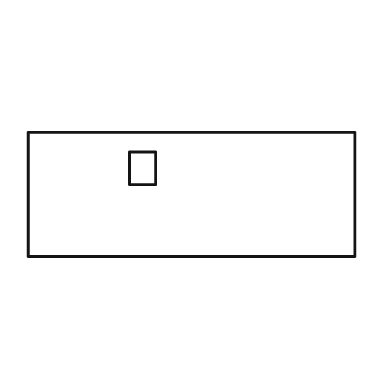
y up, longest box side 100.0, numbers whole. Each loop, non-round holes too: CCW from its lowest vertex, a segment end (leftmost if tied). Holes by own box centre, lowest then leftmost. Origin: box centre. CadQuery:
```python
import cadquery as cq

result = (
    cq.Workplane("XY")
    .moveTo(-50.0, -19.0)
    .lineTo(50.0, -19.0)
    .lineTo(50.0, 19.0)
    .lineTo(-50.0, 19.0)
    .close()
    .moveTo(-19.0, 3.0)
    .lineTo(-11.0, 3.0)
    .lineTo(-11.0, 13.0)
    .lineTo(-19.0, 13.0)
    .close()
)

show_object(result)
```